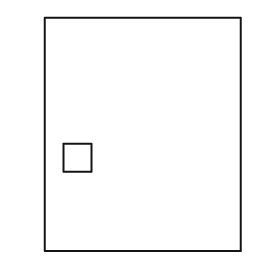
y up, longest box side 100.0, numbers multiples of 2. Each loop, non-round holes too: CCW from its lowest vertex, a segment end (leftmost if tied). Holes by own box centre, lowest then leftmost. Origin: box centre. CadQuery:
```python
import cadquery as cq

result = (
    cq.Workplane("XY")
    .moveTo(-42.0, -50.0)
    .lineTo(42.0, -50.0)
    .lineTo(42.0, 50.0)
    .lineTo(-42.0, 50.0)
    .close()
    .moveTo(-34.0, -16.0)
    .lineTo(-22.0, -16.0)
    .lineTo(-22.0, -4.0)
    .lineTo(-34.0, -4.0)
    .close()
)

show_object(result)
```